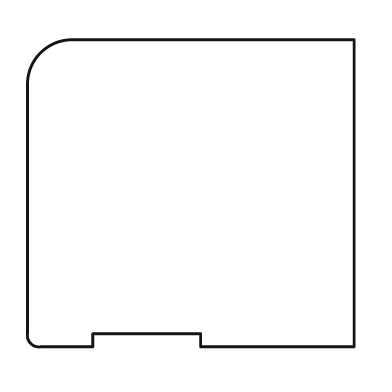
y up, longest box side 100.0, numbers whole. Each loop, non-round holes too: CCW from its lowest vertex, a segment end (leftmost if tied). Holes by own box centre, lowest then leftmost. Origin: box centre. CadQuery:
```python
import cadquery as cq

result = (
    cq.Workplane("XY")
    .moveTo(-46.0, -47.0)
    .lineTo(-30.0, -47.0)
    .lineTo(-30.0, -43.0)
    .lineTo(3.0, -43.0)
    .lineTo(3.0, -47.0)
    .lineTo(50.0, -47.0)
    .lineTo(50.0, 47.0)
    .lineTo(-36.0, 47.0)
    .threePointArc((-46.0, 43.0), (-50.0, 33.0))
    .lineTo(-50.0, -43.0)
    .threePointArc((-49.0, -46.0), (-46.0, -47.0))
    .close()
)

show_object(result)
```